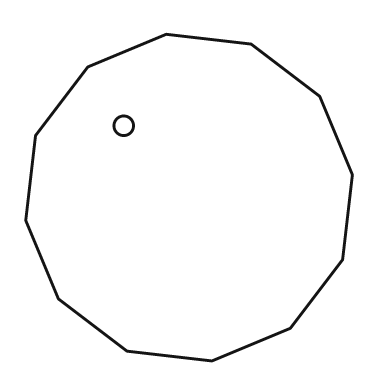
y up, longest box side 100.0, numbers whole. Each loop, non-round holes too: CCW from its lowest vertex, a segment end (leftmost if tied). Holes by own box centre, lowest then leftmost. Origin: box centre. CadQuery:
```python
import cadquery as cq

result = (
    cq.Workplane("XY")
    .moveTo(7.0, -50.0)
    .lineTo(31.0, -40.0)
    .lineTo(47.0, -19.0)
    .lineTo(50.0, 7.0)
    .lineTo(40.0, 31.0)
    .lineTo(19.0, 47.0)
    .lineTo(-7.0, 50.0)
    .lineTo(-31.0, 40.0)
    .lineTo(-47.0, 19.0)
    .lineTo(-50.0, -7.0)
    .lineTo(-40.0, -31.0)
    .lineTo(-19.0, -47.0)
    .close()
    .moveTo(-20.0, 22.0)
    .circle(3.0)
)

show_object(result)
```